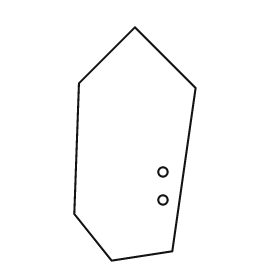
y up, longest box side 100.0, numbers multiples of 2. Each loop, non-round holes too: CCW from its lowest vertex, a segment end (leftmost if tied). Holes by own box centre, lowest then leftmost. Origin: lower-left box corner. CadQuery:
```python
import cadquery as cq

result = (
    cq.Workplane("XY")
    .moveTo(16.0, 0.0)
    .lineTo(42.0, 4.0)
    .lineTo(52.0, 74.0)
    .lineTo(26.0, 100.0)
    .lineTo(2.0, 76.0)
    .lineTo(0.0, 20.0)
    .close()
    .moveTo(38.0, 26.0)
    .circle(2.0)
    .moveTo(38.0, 38.0)
    .circle(2.0)
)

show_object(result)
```